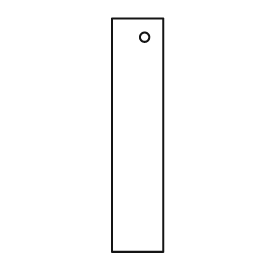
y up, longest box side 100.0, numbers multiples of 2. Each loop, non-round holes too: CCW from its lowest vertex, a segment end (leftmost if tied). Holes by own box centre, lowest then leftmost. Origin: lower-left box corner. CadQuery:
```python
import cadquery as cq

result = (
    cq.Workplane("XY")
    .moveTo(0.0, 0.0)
    .lineTo(22.0, 0.0)
    .lineTo(22.0, 100.0)
    .lineTo(0.0, 100.0)
    .close()
    .moveTo(14.0, 92.0)
    .circle(2.0)
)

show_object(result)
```